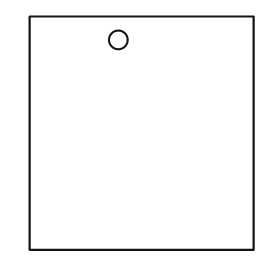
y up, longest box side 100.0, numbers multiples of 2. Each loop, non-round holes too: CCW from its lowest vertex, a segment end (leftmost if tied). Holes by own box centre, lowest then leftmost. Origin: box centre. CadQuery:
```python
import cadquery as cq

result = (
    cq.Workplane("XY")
    .moveTo(-48.0, -50.0)
    .lineTo(48.0, -50.0)
    .lineTo(48.0, 50.0)
    .lineTo(-48.0, 50.0)
    .close()
    .moveTo(-10.0, 40.0)
    .circle(4.0)
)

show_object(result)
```